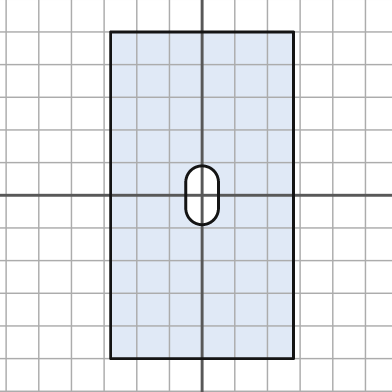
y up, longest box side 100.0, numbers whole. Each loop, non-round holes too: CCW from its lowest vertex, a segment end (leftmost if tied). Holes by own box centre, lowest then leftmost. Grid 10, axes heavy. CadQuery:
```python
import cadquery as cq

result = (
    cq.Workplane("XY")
    .moveTo(-28.0, -50.0)
    .lineTo(28.0, -50.0)
    .lineTo(28.0, 50.0)
    .lineTo(-28.0, 50.0)
    .close()
    .moveTo(-5.0, -4.0)
    .threePointArc((0.0, -9.0), (5.0, -4.0))
    .lineTo(5.0, 4.0)
    .threePointArc((0.0, 9.0), (-5.0, 4.0))
    .close()
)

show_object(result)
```